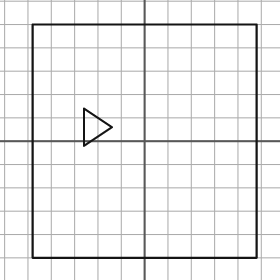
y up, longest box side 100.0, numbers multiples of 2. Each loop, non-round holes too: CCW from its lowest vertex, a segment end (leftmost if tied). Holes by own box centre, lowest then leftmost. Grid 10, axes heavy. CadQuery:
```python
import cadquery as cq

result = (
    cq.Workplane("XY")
    .moveTo(-48.0, -50.0)
    .lineTo(48.0, -50.0)
    .lineTo(48.0, 50.0)
    .lineTo(-48.0, 50.0)
    .close()
    .moveTo(-26.0, -2.0)
    .lineTo(-14.0, 6.0)
    .lineTo(-26.0, 14.0)
    .close()
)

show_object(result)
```